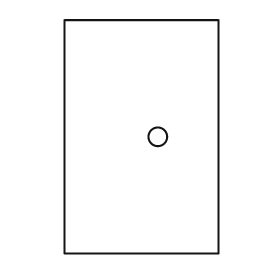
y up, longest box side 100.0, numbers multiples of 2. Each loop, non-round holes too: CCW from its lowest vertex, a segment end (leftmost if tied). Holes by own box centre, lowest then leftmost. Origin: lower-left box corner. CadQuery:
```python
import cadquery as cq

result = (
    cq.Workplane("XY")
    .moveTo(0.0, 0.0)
    .lineTo(66.0, 0.0)
    .lineTo(66.0, 100.0)
    .lineTo(0.0, 100.0)
    .close()
    .moveTo(40.0, 50.0)
    .circle(4.0)
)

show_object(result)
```